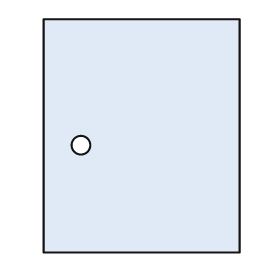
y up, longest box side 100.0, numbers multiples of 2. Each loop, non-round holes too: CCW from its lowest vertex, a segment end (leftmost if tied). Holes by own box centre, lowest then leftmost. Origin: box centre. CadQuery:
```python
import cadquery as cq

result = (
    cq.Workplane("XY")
    .moveTo(-42.0, -50.0)
    .lineTo(42.0, -50.0)
    .lineTo(42.0, 50.0)
    .lineTo(-42.0, 50.0)
    .close()
    .moveTo(-26.0, -4.0)
    .circle(4.0)
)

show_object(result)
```